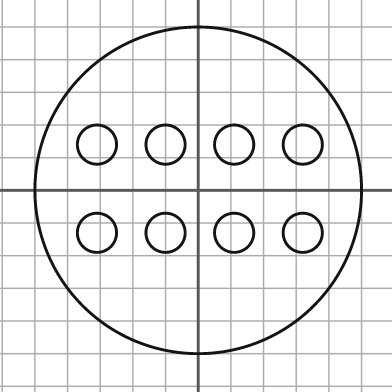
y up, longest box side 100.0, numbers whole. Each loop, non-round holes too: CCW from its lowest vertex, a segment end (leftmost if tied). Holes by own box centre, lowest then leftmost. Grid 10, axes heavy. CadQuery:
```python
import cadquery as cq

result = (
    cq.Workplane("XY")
    .moveTo(0.0, 0.0)
    .circle(50.0)
    .moveTo(-31.0, -13.0)
    .circle(6.0)
    .moveTo(-10.0, -13.0)
    .circle(6.0)
    .moveTo(11.0, -13.0)
    .circle(6.0)
    .moveTo(32.0, -13.0)
    .circle(6.0)
    .moveTo(-31.0, 14.0)
    .circle(6.0)
    .moveTo(-10.0, 14.0)
    .circle(6.0)
    .moveTo(11.0, 14.0)
    .circle(6.0)
    .moveTo(32.0, 14.0)
    .circle(6.0)
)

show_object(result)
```